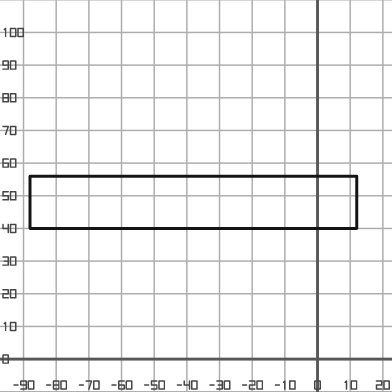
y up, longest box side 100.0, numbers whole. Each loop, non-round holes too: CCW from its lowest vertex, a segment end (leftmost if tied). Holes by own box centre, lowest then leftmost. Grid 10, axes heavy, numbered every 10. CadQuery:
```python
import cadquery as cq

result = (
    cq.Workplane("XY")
    .moveTo(-88.0, 40.0)
    .lineTo(12.0, 40.0)
    .lineTo(12.0, 56.0)
    .lineTo(-88.0, 56.0)
    .close()
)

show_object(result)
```